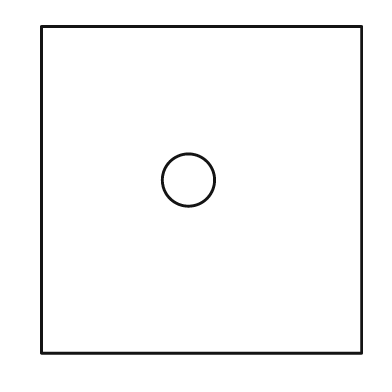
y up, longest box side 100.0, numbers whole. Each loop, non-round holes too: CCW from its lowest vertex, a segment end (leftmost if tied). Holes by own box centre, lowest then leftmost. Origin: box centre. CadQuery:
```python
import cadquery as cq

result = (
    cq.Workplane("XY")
    .moveTo(-49.0, -50.0)
    .lineTo(49.0, -50.0)
    .lineTo(49.0, 50.0)
    .lineTo(-49.0, 50.0)
    .close()
    .moveTo(-4.0, 3.0)
    .circle(8.0)
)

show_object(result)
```